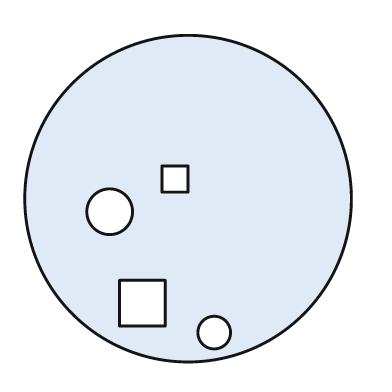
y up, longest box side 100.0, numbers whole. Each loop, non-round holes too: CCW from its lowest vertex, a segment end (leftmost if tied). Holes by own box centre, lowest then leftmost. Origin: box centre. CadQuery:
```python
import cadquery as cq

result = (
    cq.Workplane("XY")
    .moveTo(0.0, 0.0)
    .circle(50.0)
    .moveTo(8.0, -41.0)
    .circle(5.0)
    .moveTo(-21.0, -39.0)
    .lineTo(-7.0, -39.0)
    .lineTo(-7.0, -25.0)
    .lineTo(-21.0, -25.0)
    .close()
    .moveTo(-24.0, -4.0)
    .circle(7.0)
    .moveTo(-8.0, 2.0)
    .lineTo(0.0, 2.0)
    .lineTo(0.0, 10.0)
    .lineTo(-8.0, 10.0)
    .close()
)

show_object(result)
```